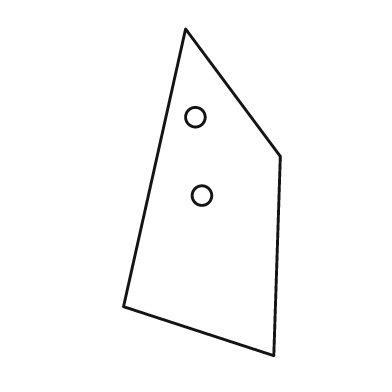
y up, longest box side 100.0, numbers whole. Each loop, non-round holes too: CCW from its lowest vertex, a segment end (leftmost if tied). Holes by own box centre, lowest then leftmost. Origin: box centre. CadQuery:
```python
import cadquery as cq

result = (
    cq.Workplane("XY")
    .moveTo(22.0, -50.0)
    .lineTo(24.0, 11.0)
    .lineTo(-5.0, 50.0)
    .lineTo(-24.0, -35.0)
    .close()
    .moveTo(0.0, -1.0)
    .circle(3.0)
    .moveTo(-2.0, 23.0)
    .circle(3.0)
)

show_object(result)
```